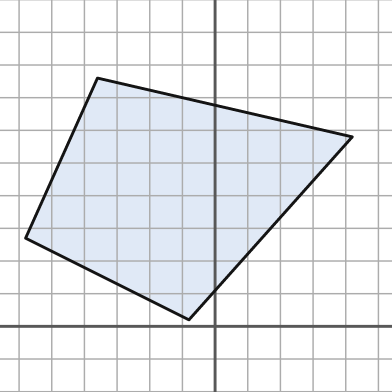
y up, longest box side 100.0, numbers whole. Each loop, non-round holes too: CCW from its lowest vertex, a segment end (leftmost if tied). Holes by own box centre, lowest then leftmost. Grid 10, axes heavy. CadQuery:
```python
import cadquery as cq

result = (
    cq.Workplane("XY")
    .moveTo(-8.0, 2.0)
    .lineTo(42.0, 58.0)
    .lineTo(-36.0, 76.0)
    .lineTo(-58.0, 27.0)
    .close()
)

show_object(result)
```